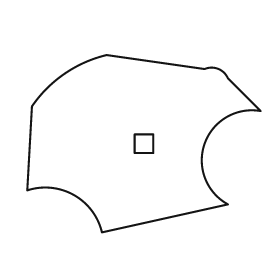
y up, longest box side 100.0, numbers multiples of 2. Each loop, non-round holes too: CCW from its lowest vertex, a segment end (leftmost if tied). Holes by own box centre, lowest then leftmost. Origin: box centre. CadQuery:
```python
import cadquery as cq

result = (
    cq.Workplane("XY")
    .moveTo(-18.0, -38.0)
    .lineTo(36.0, -26.0)
    .threePointArc((26.0, 0.0), (50.0, 14.0))
    .lineTo(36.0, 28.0)
    .threePointArc((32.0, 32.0), (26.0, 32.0))
    .lineTo(-16.0, 38.0)
    .threePointArc((-34.0, 30.0), (-48.0, 16.0))
    .lineTo(-50.0, -20.0)
    .threePointArc((-30.0, -22.0), (-18.0, -38.0))
    .close()
    .moveTo(-4.0, -4.0)
    .lineTo(4.0, -4.0)
    .lineTo(4.0, 4.0)
    .lineTo(-4.0, 4.0)
    .close()
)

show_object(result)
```